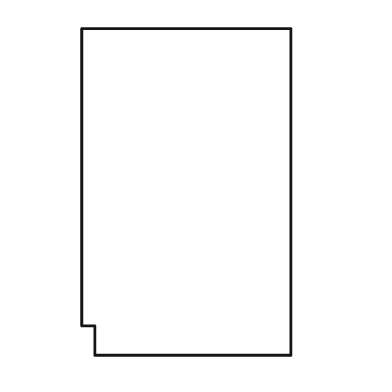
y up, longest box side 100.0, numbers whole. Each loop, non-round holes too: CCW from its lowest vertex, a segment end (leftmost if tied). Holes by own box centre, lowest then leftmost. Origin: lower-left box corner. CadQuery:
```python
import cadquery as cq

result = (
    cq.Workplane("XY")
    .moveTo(4.0, 0.0)
    .lineTo(64.0, 0.0)
    .lineTo(64.0, 100.0)
    .lineTo(0.0, 100.0)
    .lineTo(0.0, 9.0)
    .lineTo(4.0, 9.0)
    .close()
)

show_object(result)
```